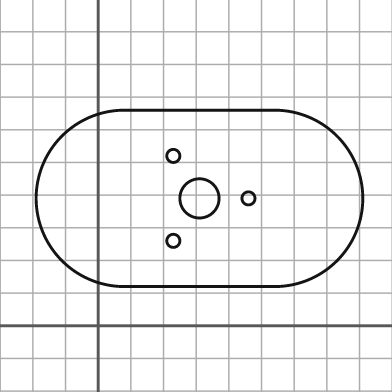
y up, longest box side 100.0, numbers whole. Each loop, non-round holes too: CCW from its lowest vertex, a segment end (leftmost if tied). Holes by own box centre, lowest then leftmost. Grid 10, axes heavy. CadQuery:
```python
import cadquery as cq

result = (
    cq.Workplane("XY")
    .moveTo(8.0, 12.0)
    .lineTo(54.0, 12.0)
    .threePointArc((81.0, 39.0), (54.0, 66.0))
    .lineTo(8.0, 66.0)
    .threePointArc((-19.0, 39.0), (8.0, 12.0))
    .close()
    .moveTo(23.0, 26.0)
    .circle(2.0)
    .moveTo(31.0, 39.0)
    .circle(6.0)
    .moveTo(46.0, 39.0)
    .circle(2.0)
    .moveTo(23.0, 52.0)
    .circle(2.0)
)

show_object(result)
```